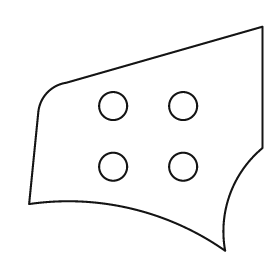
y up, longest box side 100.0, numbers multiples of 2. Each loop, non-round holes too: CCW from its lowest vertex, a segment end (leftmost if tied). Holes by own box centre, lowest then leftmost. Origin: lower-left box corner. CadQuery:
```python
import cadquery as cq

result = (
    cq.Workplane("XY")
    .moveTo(84.0, 0.0)
    .threePointArc((86.0, 24.0), (100.0, 44.0))
    .lineTo(100.0, 96.0)
    .lineTo(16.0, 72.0)
    .threePointArc((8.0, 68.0), (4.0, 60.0))
    .lineTo(0.0, 20.0)
    .threePointArc((44.0, 18.0), (84.0, 0.0))
    .close()
    .moveTo(36.0, 36.0)
    .circle(6.0)
    .moveTo(66.0, 36.0)
    .circle(6.0)
    .moveTo(36.0, 62.0)
    .circle(6.0)
    .moveTo(66.0, 62.0)
    .circle(6.0)
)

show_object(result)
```